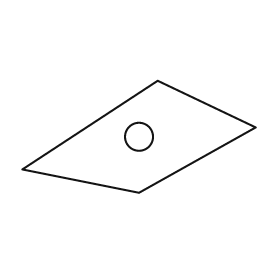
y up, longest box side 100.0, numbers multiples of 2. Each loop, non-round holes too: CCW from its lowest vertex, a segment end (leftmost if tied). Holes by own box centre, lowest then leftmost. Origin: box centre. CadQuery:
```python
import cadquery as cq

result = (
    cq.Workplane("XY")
    .moveTo(0.0, -24.0)
    .lineTo(50.0, 4.0)
    .lineTo(8.0, 24.0)
    .lineTo(-50.0, -14.0)
    .close()
    .moveTo(0.0, 0.0)
    .circle(6.0)
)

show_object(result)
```